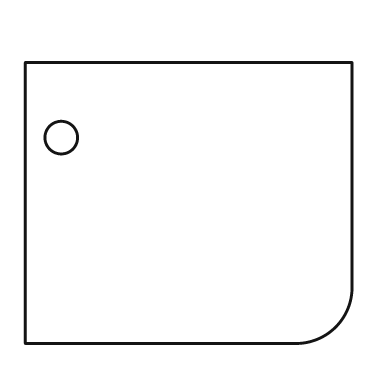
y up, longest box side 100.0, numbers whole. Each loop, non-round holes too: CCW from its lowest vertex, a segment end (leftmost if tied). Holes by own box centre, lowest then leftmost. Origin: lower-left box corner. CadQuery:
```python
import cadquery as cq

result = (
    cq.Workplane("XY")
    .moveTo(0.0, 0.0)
    .lineTo(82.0, 0.0)
    .threePointArc((95.0, 5.0), (100.0, 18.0))
    .lineTo(100.0, 86.0)
    .lineTo(0.0, 86.0)
    .close()
    .moveTo(11.0, 63.0)
    .circle(5.0)
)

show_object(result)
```